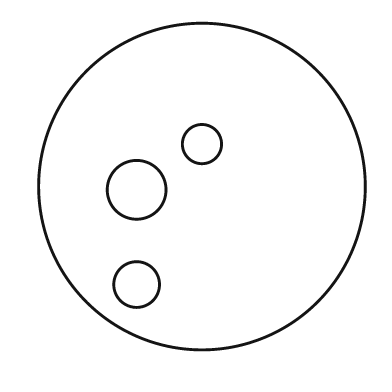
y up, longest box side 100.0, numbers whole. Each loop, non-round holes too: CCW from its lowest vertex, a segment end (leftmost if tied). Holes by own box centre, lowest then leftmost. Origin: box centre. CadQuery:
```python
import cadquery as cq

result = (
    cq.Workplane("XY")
    .moveTo(0.0, 0.0)
    .circle(50.0)
    .moveTo(-20.0, -30.0)
    .circle(7.0)
    .moveTo(-20.0, -1.0)
    .circle(9.0)
    .moveTo(0.0, 13.0)
    .circle(6.0)
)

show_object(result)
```